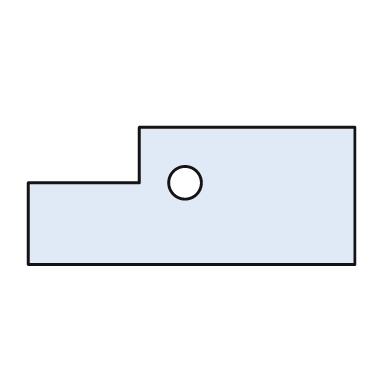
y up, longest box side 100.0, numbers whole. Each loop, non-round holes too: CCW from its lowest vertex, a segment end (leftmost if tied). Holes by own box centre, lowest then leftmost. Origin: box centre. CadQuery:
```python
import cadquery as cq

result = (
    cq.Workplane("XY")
    .moveTo(-50.0, -21.0)
    .lineTo(50.0, -21.0)
    .lineTo(50.0, 21.0)
    .lineTo(-16.0, 21.0)
    .lineTo(-16.0, 4.0)
    .lineTo(-50.0, 4.0)
    .close()
    .moveTo(-2.0, 4.0)
    .circle(5.0)
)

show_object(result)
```